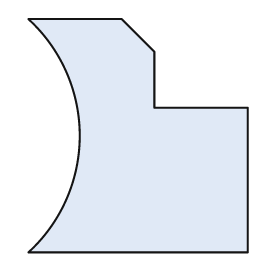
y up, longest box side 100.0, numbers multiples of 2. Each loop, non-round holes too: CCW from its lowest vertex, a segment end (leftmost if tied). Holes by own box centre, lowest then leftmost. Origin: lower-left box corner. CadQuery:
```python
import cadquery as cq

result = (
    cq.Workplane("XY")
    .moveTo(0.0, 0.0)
    .lineTo(94.0, 0.0)
    .lineTo(94.0, 62.0)
    .lineTo(54.0, 62.0)
    .lineTo(54.0, 86.0)
    .lineTo(40.0, 100.0)
    .lineTo(0.0, 100.0)
    .threePointArc((22.0, 50.0), (0.0, 0.0))
    .close()
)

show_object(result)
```